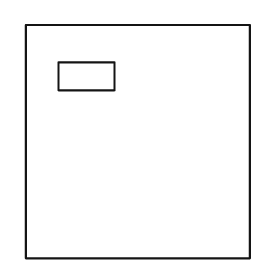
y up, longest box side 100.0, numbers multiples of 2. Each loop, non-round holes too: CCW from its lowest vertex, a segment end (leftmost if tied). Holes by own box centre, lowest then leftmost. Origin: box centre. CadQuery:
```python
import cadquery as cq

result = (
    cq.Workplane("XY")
    .moveTo(-48.0, -50.0)
    .lineTo(48.0, -50.0)
    .lineTo(48.0, 50.0)
    .lineTo(-48.0, 50.0)
    .close()
    .moveTo(-34.0, 22.0)
    .lineTo(-10.0, 22.0)
    .lineTo(-10.0, 34.0)
    .lineTo(-34.0, 34.0)
    .close()
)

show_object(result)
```